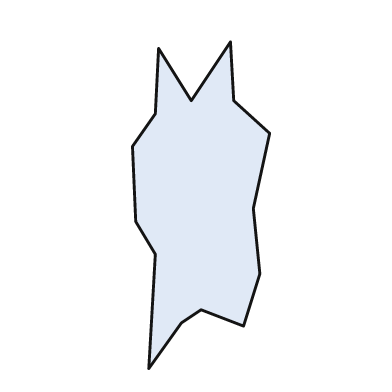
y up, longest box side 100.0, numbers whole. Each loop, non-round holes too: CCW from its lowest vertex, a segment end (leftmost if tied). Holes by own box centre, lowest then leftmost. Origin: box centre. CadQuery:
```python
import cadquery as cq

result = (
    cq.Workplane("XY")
    .moveTo(-16.0, -50.0)
    .lineTo(-6.0, -36.0)
    .lineTo(0.0, -32.0)
    .lineTo(13.0, -37.0)
    .lineTo(18.0, -21.0)
    .lineTo(16.0, -1.0)
    .lineTo(21.0, 22.0)
    .lineTo(10.0, 32.0)
    .lineTo(9.0, 50.0)
    .lineTo(-3.0, 32.0)
    .lineTo(-13.0, 48.0)
    .lineTo(-14.0, 28.0)
    .lineTo(-21.0, 18.0)
    .lineTo(-20.0, -5.0)
    .lineTo(-14.0, -15.0)
    .close()
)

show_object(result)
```